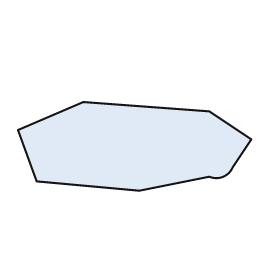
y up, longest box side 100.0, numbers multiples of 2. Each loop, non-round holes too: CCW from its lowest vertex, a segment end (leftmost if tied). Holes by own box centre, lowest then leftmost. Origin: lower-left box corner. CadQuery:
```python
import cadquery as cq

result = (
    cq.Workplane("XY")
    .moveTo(52.0, 0.0)
    .lineTo(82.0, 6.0)
    .threePointArc((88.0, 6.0), (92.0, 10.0))
    .lineTo(100.0, 22.0)
    .lineTo(82.0, 34.0)
    .lineTo(28.0, 38.0)
    .lineTo(0.0, 26.0)
    .lineTo(8.0, 4.0)
    .close()
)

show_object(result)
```